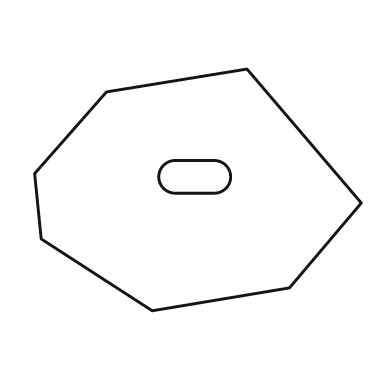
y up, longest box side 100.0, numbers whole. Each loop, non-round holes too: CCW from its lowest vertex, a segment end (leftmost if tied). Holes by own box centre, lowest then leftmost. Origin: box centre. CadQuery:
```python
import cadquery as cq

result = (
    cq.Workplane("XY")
    .moveTo(-14.0, -37.0)
    .lineTo(28.0, -30.0)
    .lineTo(50.0, -4.0)
    .lineTo(15.0, 37.0)
    .lineTo(-28.0, 30.0)
    .lineTo(-50.0, 5.0)
    .lineTo(-48.0, -15.0)
    .close()
    .moveTo(-7.0, -1.0)
    .lineTo(5.0, -1.0)
    .threePointArc((10.0, 4.0), (5.0, 9.0))
    .lineTo(-7.0, 9.0)
    .threePointArc((-12.0, 4.0), (-7.0, -1.0))
    .close()
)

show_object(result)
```